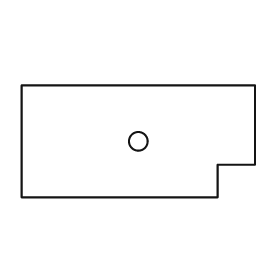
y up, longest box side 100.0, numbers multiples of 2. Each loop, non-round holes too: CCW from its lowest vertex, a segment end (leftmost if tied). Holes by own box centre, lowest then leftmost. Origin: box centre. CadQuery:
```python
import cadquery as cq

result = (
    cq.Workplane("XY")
    .moveTo(-50.0, -24.0)
    .lineTo(34.0, -24.0)
    .lineTo(34.0, -10.0)
    .lineTo(50.0, -10.0)
    .lineTo(50.0, 24.0)
    .lineTo(-50.0, 24.0)
    .close()
    .moveTo(0.0, 0.0)
    .circle(4.0)
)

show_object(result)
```